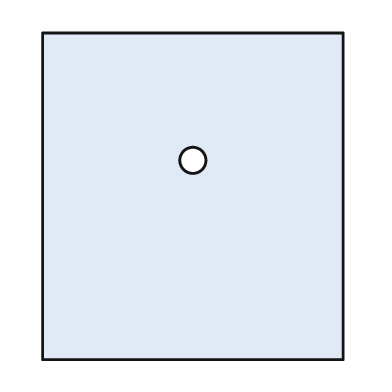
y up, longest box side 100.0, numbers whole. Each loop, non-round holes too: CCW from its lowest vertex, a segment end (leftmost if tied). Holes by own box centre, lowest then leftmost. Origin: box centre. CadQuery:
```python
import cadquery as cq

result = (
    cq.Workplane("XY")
    .moveTo(-46.0, -50.0)
    .lineTo(46.0, -50.0)
    .lineTo(46.0, 50.0)
    .lineTo(-46.0, 50.0)
    .close()
    .moveTo(0.0, 11.0)
    .circle(4.0)
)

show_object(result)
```